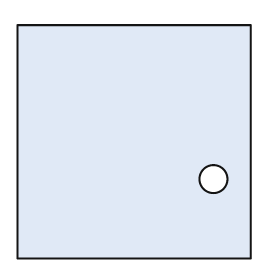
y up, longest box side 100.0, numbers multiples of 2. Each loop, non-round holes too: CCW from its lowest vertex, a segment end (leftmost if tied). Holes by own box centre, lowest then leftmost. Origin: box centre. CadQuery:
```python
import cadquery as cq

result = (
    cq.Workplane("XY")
    .moveTo(-50.0, -50.0)
    .lineTo(50.0, -50.0)
    .lineTo(50.0, 50.0)
    .lineTo(-50.0, 50.0)
    .close()
    .moveTo(34.0, -16.0)
    .circle(6.0)
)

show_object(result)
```